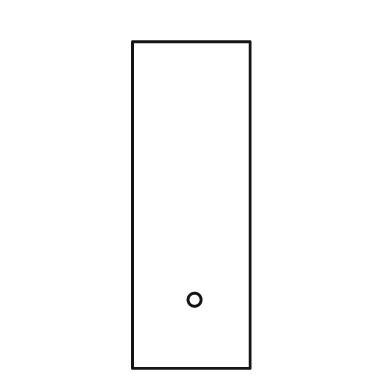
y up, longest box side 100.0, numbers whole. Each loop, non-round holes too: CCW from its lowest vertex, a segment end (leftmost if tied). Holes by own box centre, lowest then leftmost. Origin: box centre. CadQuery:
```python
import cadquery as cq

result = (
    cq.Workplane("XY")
    .moveTo(-18.0, -50.0)
    .lineTo(18.0, -50.0)
    .lineTo(18.0, 50.0)
    .lineTo(-18.0, 50.0)
    .close()
    .moveTo(1.0, -29.0)
    .circle(2.0)
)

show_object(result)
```